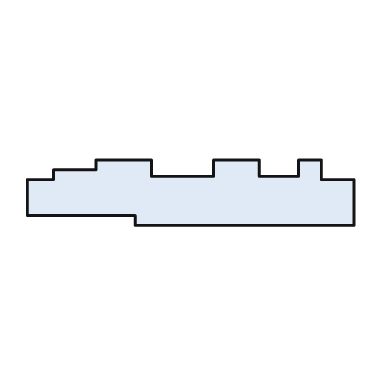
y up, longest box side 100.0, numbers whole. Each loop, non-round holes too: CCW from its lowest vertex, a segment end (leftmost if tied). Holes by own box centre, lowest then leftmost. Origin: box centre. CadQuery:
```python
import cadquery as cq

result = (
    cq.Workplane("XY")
    .moveTo(-17.0, -10.0)
    .lineTo(50.0, -10.0)
    .lineTo(50.0, 4.0)
    .lineTo(40.0, 4.0)
    .lineTo(40.0, 10.0)
    .lineTo(33.0, 10.0)
    .lineTo(33.0, 5.0)
    .lineTo(21.0, 5.0)
    .lineTo(21.0, 10.0)
    .lineTo(7.0, 10.0)
    .lineTo(7.0, 5.0)
    .lineTo(-12.0, 5.0)
    .lineTo(-12.0, 10.0)
    .lineTo(-29.0, 10.0)
    .lineTo(-29.0, 7.0)
    .lineTo(-42.0, 7.0)
    .lineTo(-42.0, 4.0)
    .lineTo(-50.0, 4.0)
    .lineTo(-50.0, -7.0)
    .lineTo(-17.0, -7.0)
    .close()
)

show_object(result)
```